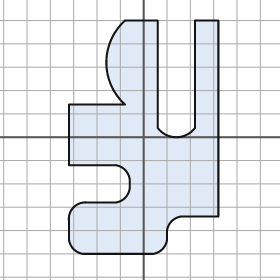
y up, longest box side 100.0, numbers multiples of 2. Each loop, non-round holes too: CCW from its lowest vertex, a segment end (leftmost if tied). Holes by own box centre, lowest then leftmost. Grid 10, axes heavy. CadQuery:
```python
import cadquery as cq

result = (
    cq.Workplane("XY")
    .moveTo(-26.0, -50.0)
    .lineTo(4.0, -50.0)
    .threePointArc((8.0, -48.0), (10.0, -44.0))
    .lineTo(10.0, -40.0)
    .threePointArc((12.0, -36.0), (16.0, -34.0))
    .lineTo(32.0, -34.0)
    .lineTo(32.0, 50.0)
    .lineTo(22.0, 50.0)
    .lineTo(22.0, 4.0)
    .threePointArc((14.0, 0.0), (6.0, 4.0))
    .lineTo(6.0, 50.0)
    .lineTo(-8.0, 50.0)
    .threePointArc((-16.0, 32.0), (-8.0, 14.0))
    .lineTo(-32.0, 14.0)
    .lineTo(-32.0, -12.0)
    .lineTo(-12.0, -12.0)
    .threePointArc((-8.0, -14.0), (-6.0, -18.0))
    .lineTo(-6.0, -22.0)
    .threePointArc((-8.0, -26.0), (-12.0, -28.0))
    .lineTo(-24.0, -28.0)
    .threePointArc((-30.0, -30.0), (-32.0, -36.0))
    .lineTo(-32.0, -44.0)
    .threePointArc((-30.0, -48.0), (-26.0, -50.0))
    .close()
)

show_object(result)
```